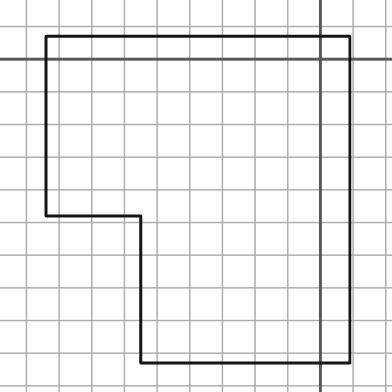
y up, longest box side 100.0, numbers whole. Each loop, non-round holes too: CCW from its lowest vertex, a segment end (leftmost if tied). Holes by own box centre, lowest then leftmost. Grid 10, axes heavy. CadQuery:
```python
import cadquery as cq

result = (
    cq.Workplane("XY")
    .moveTo(-55.0, -93.0)
    .lineTo(9.0, -93.0)
    .lineTo(9.0, 7.0)
    .lineTo(-84.0, 7.0)
    .lineTo(-84.0, -48.0)
    .lineTo(-55.0, -48.0)
    .close()
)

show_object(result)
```